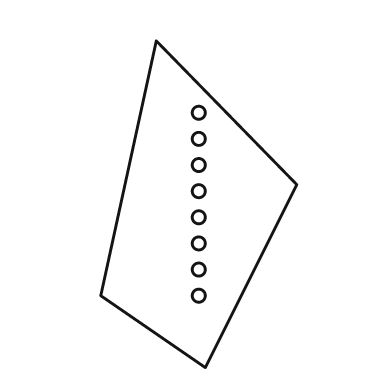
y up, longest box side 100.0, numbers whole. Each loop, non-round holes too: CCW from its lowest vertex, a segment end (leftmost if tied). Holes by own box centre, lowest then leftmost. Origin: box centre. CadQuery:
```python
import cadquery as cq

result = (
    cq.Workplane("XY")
    .moveTo(2.0, -50.0)
    .lineTo(30.0, 6.0)
    .lineTo(-13.0, 50.0)
    .lineTo(-30.0, -28.0)
    .close()
    .moveTo(0.0, -28.0)
    .circle(2.0)
    .moveTo(0.0, -20.0)
    .circle(2.0)
    .moveTo(0.0, -12.0)
    .circle(2.0)
    .moveTo(0.0, -4.0)
    .circle(2.0)
    .moveTo(0.0, 4.0)
    .circle(2.0)
    .moveTo(0.0, 12.0)
    .circle(2.0)
    .moveTo(0.0, 20.0)
    .circle(2.0)
    .moveTo(0.0, 28.0)
    .circle(2.0)
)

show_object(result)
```